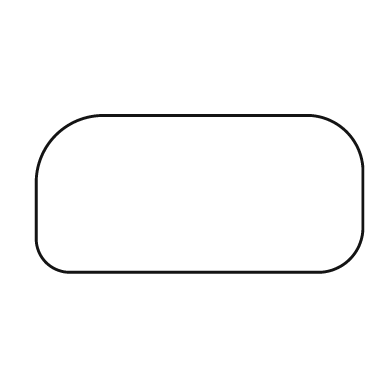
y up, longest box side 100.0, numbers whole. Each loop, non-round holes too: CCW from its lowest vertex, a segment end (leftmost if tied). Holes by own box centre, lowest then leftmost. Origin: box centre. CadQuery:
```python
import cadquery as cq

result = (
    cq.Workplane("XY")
    .moveTo(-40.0, -24.0)
    .lineTo(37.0, -24.0)
    .threePointArc((46.0, -20.0), (50.0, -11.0))
    .lineTo(50.0, 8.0)
    .threePointArc((45.0, 19.0), (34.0, 24.0))
    .lineTo(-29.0, 24.0)
    .threePointArc((-44.0, 18.0), (-50.0, 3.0))
    .lineTo(-50.0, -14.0)
    .threePointArc((-47.0, -21.0), (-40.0, -24.0))
    .close()
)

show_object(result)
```